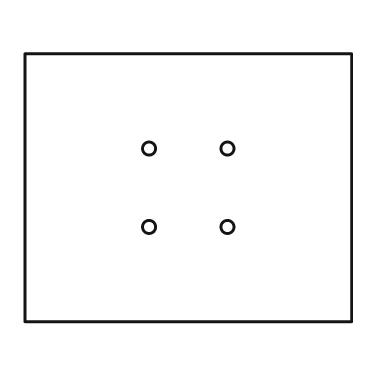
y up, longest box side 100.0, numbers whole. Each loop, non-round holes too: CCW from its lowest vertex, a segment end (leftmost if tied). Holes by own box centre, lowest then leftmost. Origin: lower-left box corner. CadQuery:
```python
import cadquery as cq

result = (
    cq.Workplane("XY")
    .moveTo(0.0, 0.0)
    .lineTo(100.0, 0.0)
    .lineTo(100.0, 82.0)
    .lineTo(0.0, 82.0)
    .close()
    .moveTo(38.0, 29.0)
    .circle(2.0)
    .moveTo(62.0, 29.0)
    .circle(2.0)
    .moveTo(38.0, 53.0)
    .circle(2.0)
    .moveTo(62.0, 53.0)
    .circle(2.0)
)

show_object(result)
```